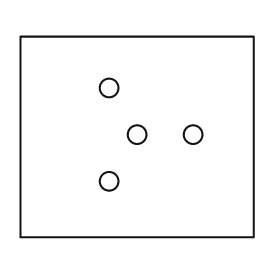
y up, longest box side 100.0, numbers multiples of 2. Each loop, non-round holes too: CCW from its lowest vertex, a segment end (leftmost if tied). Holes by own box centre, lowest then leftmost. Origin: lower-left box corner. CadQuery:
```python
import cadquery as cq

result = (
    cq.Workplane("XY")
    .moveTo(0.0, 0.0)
    .lineTo(100.0, 0.0)
    .lineTo(100.0, 86.0)
    .lineTo(0.0, 86.0)
    .close()
    .moveTo(38.0, 24.0)
    .circle(4.0)
    .moveTo(50.0, 44.0)
    .circle(4.0)
    .moveTo(74.0, 44.0)
    .circle(4.0)
    .moveTo(38.0, 64.0)
    .circle(4.0)
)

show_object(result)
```